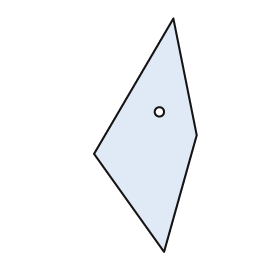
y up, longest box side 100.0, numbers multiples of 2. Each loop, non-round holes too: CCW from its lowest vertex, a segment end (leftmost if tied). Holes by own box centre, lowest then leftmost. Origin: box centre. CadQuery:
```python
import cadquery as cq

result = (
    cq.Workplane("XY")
    .moveTo(8.0, -50.0)
    .lineTo(22.0, 0.0)
    .lineTo(12.0, 50.0)
    .lineTo(-22.0, -8.0)
    .close()
    .moveTo(6.0, 10.0)
    .circle(2.0)
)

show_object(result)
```